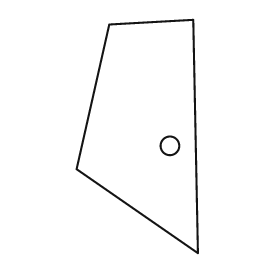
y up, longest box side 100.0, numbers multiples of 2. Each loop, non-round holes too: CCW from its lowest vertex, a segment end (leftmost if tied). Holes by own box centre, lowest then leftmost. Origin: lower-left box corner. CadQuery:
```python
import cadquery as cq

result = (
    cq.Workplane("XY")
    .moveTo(52.0, 0.0)
    .lineTo(50.0, 100.0)
    .lineTo(14.0, 98.0)
    .lineTo(0.0, 36.0)
    .close()
    .moveTo(40.0, 46.0)
    .circle(4.0)
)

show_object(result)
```